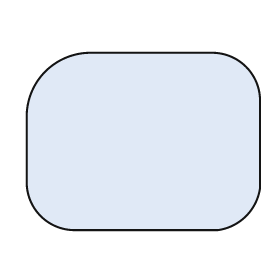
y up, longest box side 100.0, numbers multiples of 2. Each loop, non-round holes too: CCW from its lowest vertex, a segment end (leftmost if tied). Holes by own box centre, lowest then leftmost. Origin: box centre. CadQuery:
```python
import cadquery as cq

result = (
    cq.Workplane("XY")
    .moveTo(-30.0, -38.0)
    .lineTo(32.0, -38.0)
    .threePointArc((44.0, -32.0), (50.0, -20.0))
    .lineTo(50.0, 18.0)
    .threePointArc((44.0, 32.0), (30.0, 38.0))
    .lineTo(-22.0, 38.0)
    .threePointArc((-42.0, 30.0), (-50.0, 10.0))
    .lineTo(-50.0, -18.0)
    .threePointArc((-44.0, -32.0), (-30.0, -38.0))
    .close()
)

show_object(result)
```